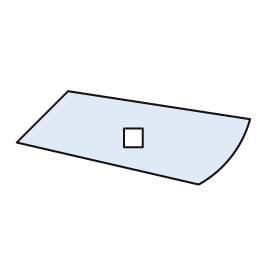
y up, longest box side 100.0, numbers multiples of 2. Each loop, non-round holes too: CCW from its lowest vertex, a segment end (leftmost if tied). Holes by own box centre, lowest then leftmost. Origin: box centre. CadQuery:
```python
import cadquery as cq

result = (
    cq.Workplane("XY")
    .moveTo(28.0, -20.0)
    .threePointArc((42.0, -8.0), (50.0, 8.0))
    .lineTo(-28.0, 20.0)
    .lineTo(-50.0, -2.0)
    .close()
    .moveTo(-4.0, -4.0)
    .lineTo(4.0, -4.0)
    .lineTo(4.0, 4.0)
    .lineTo(-4.0, 4.0)
    .close()
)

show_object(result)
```